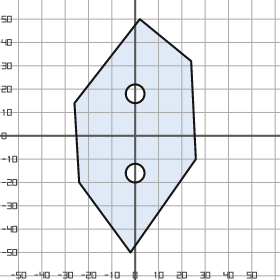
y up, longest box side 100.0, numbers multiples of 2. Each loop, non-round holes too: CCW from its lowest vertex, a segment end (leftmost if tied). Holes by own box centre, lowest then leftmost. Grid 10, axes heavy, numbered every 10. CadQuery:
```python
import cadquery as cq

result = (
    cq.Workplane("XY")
    .moveTo(-2.0, -50.0)
    .lineTo(26.0, -10.0)
    .lineTo(24.0, 32.0)
    .lineTo(2.0, 50.0)
    .lineTo(-26.0, 14.0)
    .lineTo(-24.0, -20.0)
    .close()
    .moveTo(0.0, -16.0)
    .circle(4.0)
    .moveTo(0.0, 18.0)
    .circle(4.0)
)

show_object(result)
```